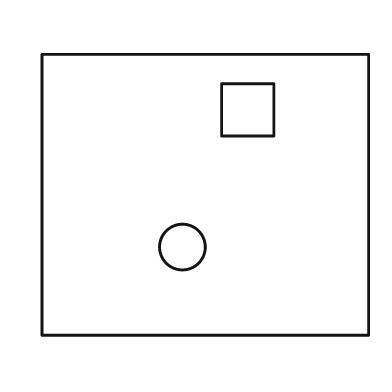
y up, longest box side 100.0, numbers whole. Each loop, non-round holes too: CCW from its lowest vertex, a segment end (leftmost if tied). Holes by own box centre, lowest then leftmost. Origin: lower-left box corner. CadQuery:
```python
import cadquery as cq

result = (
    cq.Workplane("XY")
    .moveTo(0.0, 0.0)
    .lineTo(100.0, 0.0)
    .lineTo(100.0, 86.0)
    .lineTo(0.0, 86.0)
    .close()
    .moveTo(43.0, 27.0)
    .circle(7.0)
    .moveTo(55.0, 61.0)
    .lineTo(71.0, 61.0)
    .lineTo(71.0, 77.0)
    .lineTo(55.0, 77.0)
    .close()
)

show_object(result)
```